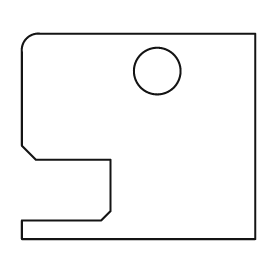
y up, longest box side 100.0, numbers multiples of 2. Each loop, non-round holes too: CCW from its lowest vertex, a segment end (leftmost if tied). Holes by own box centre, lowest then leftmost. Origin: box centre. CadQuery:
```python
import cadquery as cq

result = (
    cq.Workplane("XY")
    .moveTo(-50.0, -44.0)
    .lineTo(50.0, -44.0)
    .lineTo(50.0, 44.0)
    .lineTo(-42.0, 44.0)
    .threePointArc((-48.0, 42.0), (-50.0, 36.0))
    .lineTo(-50.0, -4.0)
    .lineTo(-44.0, -10.0)
    .lineTo(-12.0, -10.0)
    .lineTo(-12.0, -32.0)
    .lineTo(-16.0, -36.0)
    .lineTo(-50.0, -36.0)
    .close()
    .moveTo(8.0, 28.0)
    .circle(10.0)
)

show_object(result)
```